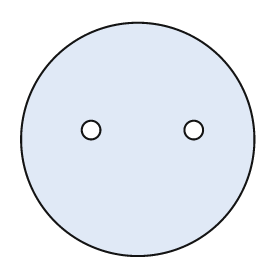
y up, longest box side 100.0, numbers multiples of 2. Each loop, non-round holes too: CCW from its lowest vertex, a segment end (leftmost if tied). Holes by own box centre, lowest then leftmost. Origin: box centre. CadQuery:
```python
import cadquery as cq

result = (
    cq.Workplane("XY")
    .moveTo(0.0, 0.0)
    .circle(50.0)
    .moveTo(-20.0, 4.0)
    .circle(4.0)
    .moveTo(24.0, 4.0)
    .circle(4.0)
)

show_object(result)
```